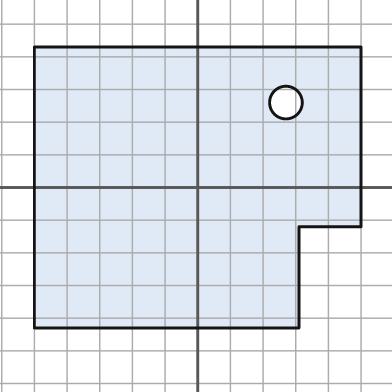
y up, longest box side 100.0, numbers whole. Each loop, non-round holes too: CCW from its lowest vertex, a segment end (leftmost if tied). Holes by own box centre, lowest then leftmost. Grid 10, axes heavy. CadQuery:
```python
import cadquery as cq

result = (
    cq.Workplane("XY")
    .moveTo(-50.0, -43.0)
    .lineTo(31.0, -43.0)
    .lineTo(31.0, -12.0)
    .lineTo(50.0, -12.0)
    .lineTo(50.0, 43.0)
    .lineTo(-50.0, 43.0)
    .close()
    .moveTo(27.0, 26.0)
    .circle(5.0)
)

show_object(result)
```